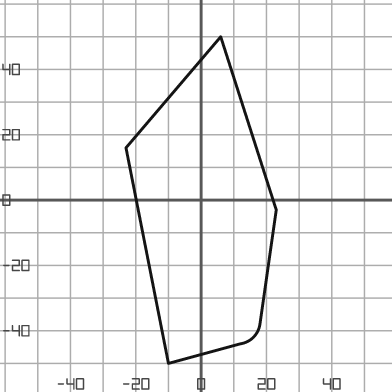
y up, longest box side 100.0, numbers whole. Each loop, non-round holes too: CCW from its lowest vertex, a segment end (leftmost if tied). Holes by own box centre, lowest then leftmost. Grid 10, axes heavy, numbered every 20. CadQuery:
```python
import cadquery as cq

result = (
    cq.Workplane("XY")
    .moveTo(-10.0, -50.0)
    .lineTo(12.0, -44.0)
    .threePointArc((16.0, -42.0), (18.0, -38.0))
    .lineTo(23.0, -3.0)
    .lineTo(6.0, 50.0)
    .lineTo(-23.0, 16.0)
    .close()
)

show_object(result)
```